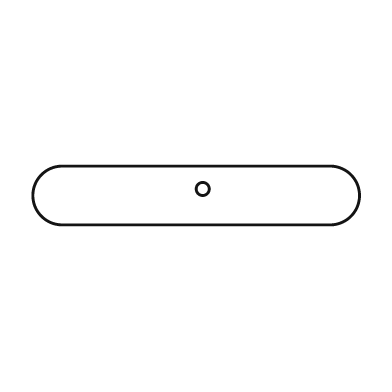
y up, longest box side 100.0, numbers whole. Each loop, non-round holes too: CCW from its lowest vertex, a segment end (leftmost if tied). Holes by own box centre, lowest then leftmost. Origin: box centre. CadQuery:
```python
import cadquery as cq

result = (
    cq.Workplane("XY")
    .moveTo(-41.0, -9.0)
    .lineTo(41.0, -9.0)
    .threePointArc((50.0, 0.0), (41.0, 9.0))
    .lineTo(-41.0, 9.0)
    .threePointArc((-50.0, 0.0), (-41.0, -9.0))
    .close()
    .moveTo(2.0, 2.0)
    .circle(2.0)
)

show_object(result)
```